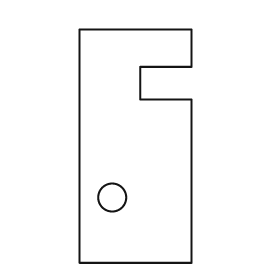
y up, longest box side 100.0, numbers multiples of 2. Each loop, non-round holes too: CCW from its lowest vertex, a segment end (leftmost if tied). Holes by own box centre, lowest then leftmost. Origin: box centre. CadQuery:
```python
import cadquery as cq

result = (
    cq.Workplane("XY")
    .moveTo(-24.0, -50.0)
    .lineTo(24.0, -50.0)
    .lineTo(24.0, 20.0)
    .lineTo(2.0, 20.0)
    .lineTo(2.0, 34.0)
    .lineTo(24.0, 34.0)
    .lineTo(24.0, 50.0)
    .lineTo(-24.0, 50.0)
    .close()
    .moveTo(-10.0, -22.0)
    .circle(6.0)
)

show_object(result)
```